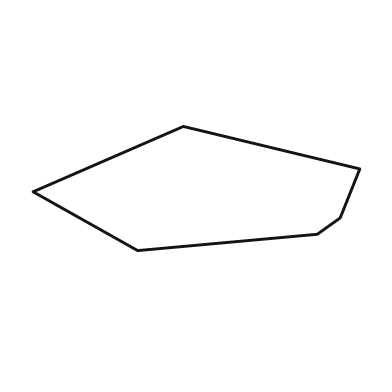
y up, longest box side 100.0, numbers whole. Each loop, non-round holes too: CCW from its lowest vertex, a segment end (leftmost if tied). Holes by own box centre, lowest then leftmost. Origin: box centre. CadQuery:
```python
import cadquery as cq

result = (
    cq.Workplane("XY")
    .moveTo(-18.0, -19.0)
    .lineTo(37.0, -14.0)
    .lineTo(44.0, -9.0)
    .lineTo(50.0, 6.0)
    .lineTo(-4.0, 19.0)
    .lineTo(-50.0, -1.0)
    .close()
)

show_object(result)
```